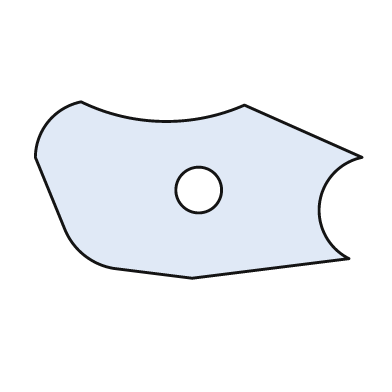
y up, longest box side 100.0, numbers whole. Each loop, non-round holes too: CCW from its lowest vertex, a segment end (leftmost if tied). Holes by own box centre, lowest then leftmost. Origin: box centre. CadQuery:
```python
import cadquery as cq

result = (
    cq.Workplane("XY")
    .moveTo(-2.0, -27.0)
    .lineTo(46.0, -21.0)
    .threePointArc((37.0, -4.0), (50.0, 10.0))
    .lineTo(14.0, 26.0)
    .threePointArc((-11.0, 21.0), (-36.0, 27.0))
    .threePointArc((-46.0, 21.0), (-50.0, 10.0))
    .lineTo(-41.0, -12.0)
    .threePointArc((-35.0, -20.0), (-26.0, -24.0))
    .close()
    .moveTo(0.0, 0.0)
    .circle(7.0)
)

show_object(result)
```